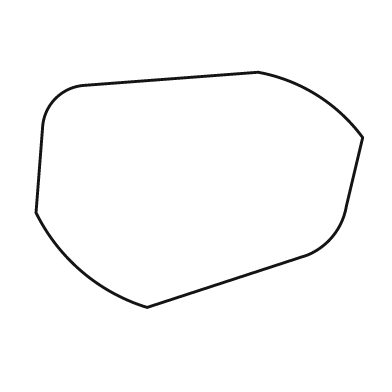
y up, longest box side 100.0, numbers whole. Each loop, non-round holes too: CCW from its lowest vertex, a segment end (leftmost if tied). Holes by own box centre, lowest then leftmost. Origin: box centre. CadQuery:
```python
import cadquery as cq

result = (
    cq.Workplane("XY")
    .moveTo(-16.0, -36.0)
    .lineTo(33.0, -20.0)
    .threePointArc((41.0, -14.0), (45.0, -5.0))
    .lineTo(50.0, 16.0)
    .threePointArc((36.0, 29.0), (18.0, 36.0))
    .lineTo(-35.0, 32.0)
    .threePointArc((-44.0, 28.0), (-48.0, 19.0))
    .lineTo(-50.0, -7.0)
    .threePointArc((-36.0, -25.0), (-16.0, -36.0))
    .close()
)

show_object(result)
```